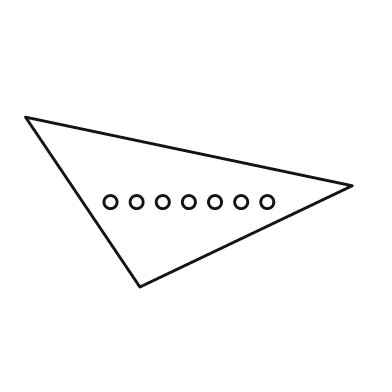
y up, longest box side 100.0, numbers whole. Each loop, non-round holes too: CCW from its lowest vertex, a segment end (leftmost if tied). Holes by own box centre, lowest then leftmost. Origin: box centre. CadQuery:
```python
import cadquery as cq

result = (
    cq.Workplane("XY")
    .moveTo(-15.0, -26.0)
    .lineTo(50.0, 5.0)
    .lineTo(-50.0, 26.0)
    .close()
    .moveTo(-24.0, 0.0)
    .circle(2.0)
    .moveTo(-16.0, 0.0)
    .circle(2.0)
    .moveTo(-8.0, 0.0)
    .circle(2.0)
    .moveTo(0.0, 0.0)
    .circle(2.0)
    .moveTo(8.0, 0.0)
    .circle(2.0)
    .moveTo(16.0, 0.0)
    .circle(2.0)
    .moveTo(24.0, 0.0)
    .circle(2.0)
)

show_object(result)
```